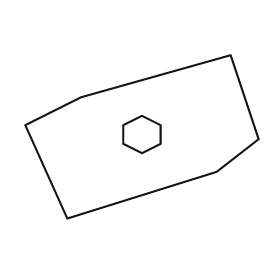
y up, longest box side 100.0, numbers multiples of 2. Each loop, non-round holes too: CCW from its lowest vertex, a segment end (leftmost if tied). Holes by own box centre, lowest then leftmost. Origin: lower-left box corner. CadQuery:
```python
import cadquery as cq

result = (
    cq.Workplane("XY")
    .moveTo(18.0, 0.0)
    .lineTo(82.0, 20.0)
    .lineTo(100.0, 34.0)
    .lineTo(88.0, 70.0)
    .lineTo(24.0, 52.0)
    .lineTo(0.0, 40.0)
    .close()
    .moveTo(50.0, 28.0)
    .lineTo(58.0, 32.0)
    .lineTo(58.0, 40.0)
    .lineTo(50.0, 44.0)
    .lineTo(42.0, 40.0)
    .lineTo(42.0, 32.0)
    .close()
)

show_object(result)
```